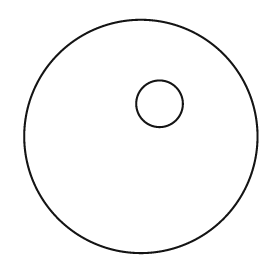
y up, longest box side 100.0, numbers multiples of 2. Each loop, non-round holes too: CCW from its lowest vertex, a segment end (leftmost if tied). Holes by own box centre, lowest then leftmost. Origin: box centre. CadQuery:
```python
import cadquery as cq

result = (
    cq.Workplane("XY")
    .moveTo(0.0, 0.0)
    .circle(50.0)
    .moveTo(8.0, 14.0)
    .circle(10.0)
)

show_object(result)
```